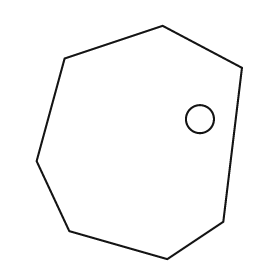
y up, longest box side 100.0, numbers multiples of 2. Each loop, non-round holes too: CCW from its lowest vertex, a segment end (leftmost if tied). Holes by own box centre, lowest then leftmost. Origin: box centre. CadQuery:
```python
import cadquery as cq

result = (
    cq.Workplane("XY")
    .moveTo(12.0, -50.0)
    .lineTo(36.0, -34.0)
    .lineTo(44.0, 32.0)
    .lineTo(10.0, 50.0)
    .lineTo(-32.0, 36.0)
    .lineTo(-44.0, -8.0)
    .lineTo(-30.0, -38.0)
    .close()
    .moveTo(26.0, 10.0)
    .circle(6.0)
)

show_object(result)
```